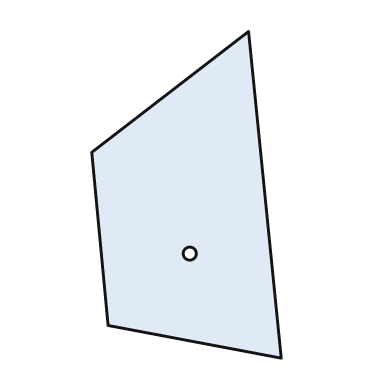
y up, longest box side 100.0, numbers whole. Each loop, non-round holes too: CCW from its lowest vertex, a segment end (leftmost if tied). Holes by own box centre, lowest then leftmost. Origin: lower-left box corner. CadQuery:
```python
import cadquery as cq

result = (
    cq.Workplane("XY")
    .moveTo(58.0, 0.0)
    .lineTo(48.0, 100.0)
    .lineTo(0.0, 63.0)
    .lineTo(5.0, 10.0)
    .close()
    .moveTo(30.0, 32.0)
    .circle(2.0)
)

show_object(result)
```